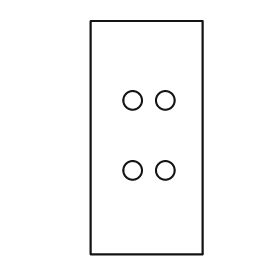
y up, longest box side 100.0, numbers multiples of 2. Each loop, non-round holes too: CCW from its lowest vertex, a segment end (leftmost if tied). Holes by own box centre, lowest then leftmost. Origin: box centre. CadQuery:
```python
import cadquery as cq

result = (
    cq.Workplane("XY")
    .moveTo(-24.0, -50.0)
    .lineTo(24.0, -50.0)
    .lineTo(24.0, 50.0)
    .lineTo(-24.0, 50.0)
    .close()
    .moveTo(-6.0, -14.0)
    .circle(4.0)
    .moveTo(8.0, -14.0)
    .circle(4.0)
    .moveTo(-6.0, 16.0)
    .circle(4.0)
    .moveTo(8.0, 16.0)
    .circle(4.0)
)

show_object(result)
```